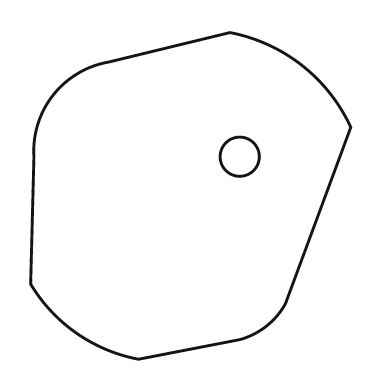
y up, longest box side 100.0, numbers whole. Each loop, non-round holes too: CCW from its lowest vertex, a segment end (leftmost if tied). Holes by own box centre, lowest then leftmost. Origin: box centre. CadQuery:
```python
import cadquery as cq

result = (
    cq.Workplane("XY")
    .moveTo(-16.0, -50.0)
    .lineTo(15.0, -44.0)
    .threePointArc((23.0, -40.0), (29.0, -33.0))
    .lineTo(49.0, 21.0)
    .threePointArc((34.0, 40.0), (12.0, 50.0))
    .lineTo(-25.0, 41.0)
    .threePointArc((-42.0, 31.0), (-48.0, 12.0))
    .lineTo(-49.0, -27.0)
    .threePointArc((-35.0, -42.0), (-16.0, -50.0))
    .close()
    .moveTo(15.0, 12.0)
    .circle(6.0)
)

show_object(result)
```